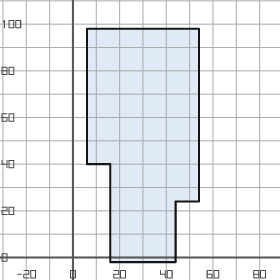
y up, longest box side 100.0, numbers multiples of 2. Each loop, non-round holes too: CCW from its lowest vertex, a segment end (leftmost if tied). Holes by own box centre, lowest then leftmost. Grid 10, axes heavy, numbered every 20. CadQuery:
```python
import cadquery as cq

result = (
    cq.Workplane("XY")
    .moveTo(16.0, -2.0)
    .lineTo(44.0, -2.0)
    .lineTo(44.0, 24.0)
    .lineTo(54.0, 24.0)
    .lineTo(54.0, 98.0)
    .lineTo(6.0, 98.0)
    .lineTo(6.0, 40.0)
    .lineTo(16.0, 40.0)
    .close()
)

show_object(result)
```